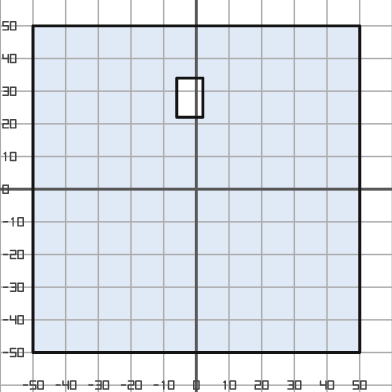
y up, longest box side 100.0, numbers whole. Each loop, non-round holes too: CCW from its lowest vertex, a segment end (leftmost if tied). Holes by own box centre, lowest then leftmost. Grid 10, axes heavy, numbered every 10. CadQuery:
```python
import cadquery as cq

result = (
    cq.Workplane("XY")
    .moveTo(-50.0, -50.0)
    .lineTo(50.0, -50.0)
    .lineTo(50.0, 50.0)
    .lineTo(-50.0, 50.0)
    .close()
    .moveTo(-6.0, 22.0)
    .lineTo(2.0, 22.0)
    .lineTo(2.0, 34.0)
    .lineTo(-6.0, 34.0)
    .close()
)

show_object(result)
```